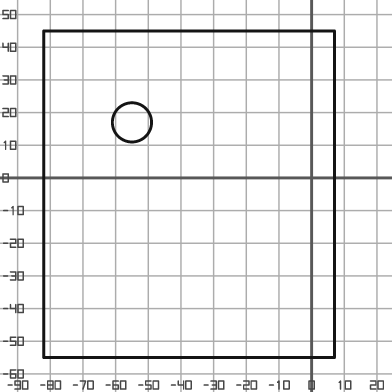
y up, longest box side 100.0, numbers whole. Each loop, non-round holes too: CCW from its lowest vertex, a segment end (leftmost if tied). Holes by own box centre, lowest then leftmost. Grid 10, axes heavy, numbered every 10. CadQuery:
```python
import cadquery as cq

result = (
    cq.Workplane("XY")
    .moveTo(-82.0, -55.0)
    .lineTo(7.0, -55.0)
    .lineTo(7.0, 45.0)
    .lineTo(-82.0, 45.0)
    .close()
    .moveTo(-55.0, 17.0)
    .circle(6.0)
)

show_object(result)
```